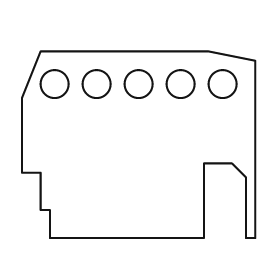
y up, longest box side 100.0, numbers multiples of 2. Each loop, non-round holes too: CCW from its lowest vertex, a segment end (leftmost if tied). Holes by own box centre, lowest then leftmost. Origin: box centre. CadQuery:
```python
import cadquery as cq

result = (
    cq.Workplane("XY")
    .moveTo(-38.0, -40.0)
    .lineTo(28.0, -40.0)
    .lineTo(28.0, -8.0)
    .lineTo(40.0, -8.0)
    .lineTo(46.0, -14.0)
    .lineTo(46.0, -40.0)
    .lineTo(50.0, -40.0)
    .lineTo(50.0, 36.0)
    .lineTo(30.0, 40.0)
    .lineTo(-42.0, 40.0)
    .lineTo(-50.0, 20.0)
    .lineTo(-50.0, -12.0)
    .lineTo(-42.0, -12.0)
    .lineTo(-42.0, -28.0)
    .lineTo(-38.0, -28.0)
    .close()
    .moveTo(-36.0, 26.0)
    .circle(6.0)
    .moveTo(-18.0, 26.0)
    .circle(6.0)
    .moveTo(0.0, 26.0)
    .circle(6.0)
    .moveTo(18.0, 26.0)
    .circle(6.0)
    .moveTo(36.0, 26.0)
    .circle(6.0)
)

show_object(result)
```